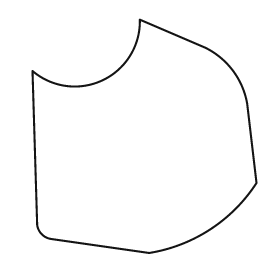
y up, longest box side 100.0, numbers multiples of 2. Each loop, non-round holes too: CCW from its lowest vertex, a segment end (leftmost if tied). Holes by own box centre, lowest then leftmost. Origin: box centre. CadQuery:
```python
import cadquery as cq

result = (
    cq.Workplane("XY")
    .moveTo(2.0, -50.0)
    .threePointArc((28.0, -40.0), (48.0, -20.0))
    .lineTo(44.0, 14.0)
    .threePointArc((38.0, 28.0), (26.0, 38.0))
    .lineTo(-2.0, 50.0)
    .threePointArc((-18.0, 24.0), (-48.0, 28.0))
    .lineTo(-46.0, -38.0)
    .threePointArc((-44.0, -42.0), (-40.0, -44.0))
    .close()
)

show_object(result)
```